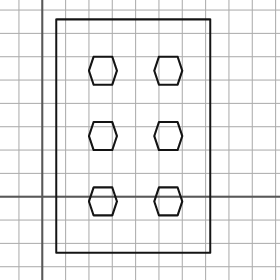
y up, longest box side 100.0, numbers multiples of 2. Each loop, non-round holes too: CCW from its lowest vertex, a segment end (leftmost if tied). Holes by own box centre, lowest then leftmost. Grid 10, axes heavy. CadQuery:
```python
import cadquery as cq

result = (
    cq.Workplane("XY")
    .moveTo(6.0, -24.0)
    .lineTo(72.0, -24.0)
    .lineTo(72.0, 76.0)
    .lineTo(6.0, 76.0)
    .close()
    .moveTo(22.0, -8.0)
    .lineTo(30.0, -8.0)
    .lineTo(32.0, -2.0)
    .lineTo(30.0, 4.0)
    .lineTo(22.0, 4.0)
    .lineTo(20.0, -2.0)
    .close()
    .moveTo(50.0, -8.0)
    .lineTo(58.0, -8.0)
    .lineTo(60.0, -2.0)
    .lineTo(58.0, 4.0)
    .lineTo(50.0, 4.0)
    .lineTo(48.0, -2.0)
    .close()
    .moveTo(22.0, 20.0)
    .lineTo(30.0, 20.0)
    .lineTo(32.0, 26.0)
    .lineTo(30.0, 32.0)
    .lineTo(22.0, 32.0)
    .lineTo(20.0, 26.0)
    .close()
    .moveTo(50.0, 20.0)
    .lineTo(58.0, 20.0)
    .lineTo(60.0, 26.0)
    .lineTo(58.0, 32.0)
    .lineTo(50.0, 32.0)
    .lineTo(48.0, 26.0)
    .close()
    .moveTo(22.0, 48.0)
    .lineTo(30.0, 48.0)
    .lineTo(32.0, 54.0)
    .lineTo(30.0, 60.0)
    .lineTo(22.0, 60.0)
    .lineTo(20.0, 54.0)
    .close()
    .moveTo(50.0, 48.0)
    .lineTo(58.0, 48.0)
    .lineTo(60.0, 54.0)
    .lineTo(58.0, 60.0)
    .lineTo(50.0, 60.0)
    .lineTo(48.0, 54.0)
    .close()
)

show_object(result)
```